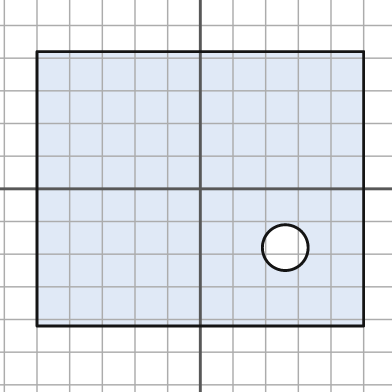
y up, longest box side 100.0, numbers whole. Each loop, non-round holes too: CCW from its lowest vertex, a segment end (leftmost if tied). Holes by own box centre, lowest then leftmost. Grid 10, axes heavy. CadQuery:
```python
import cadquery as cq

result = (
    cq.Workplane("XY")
    .moveTo(-50.0, -42.0)
    .lineTo(50.0, -42.0)
    .lineTo(50.0, 42.0)
    .lineTo(-50.0, 42.0)
    .close()
    .moveTo(26.0, -18.0)
    .circle(7.0)
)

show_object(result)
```